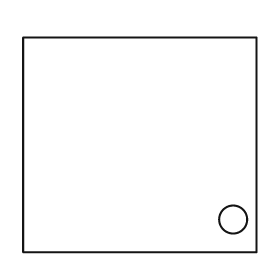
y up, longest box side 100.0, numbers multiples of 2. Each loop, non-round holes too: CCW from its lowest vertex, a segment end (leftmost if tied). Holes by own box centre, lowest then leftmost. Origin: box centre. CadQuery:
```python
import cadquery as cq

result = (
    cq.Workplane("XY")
    .moveTo(-50.0, -46.0)
    .lineTo(50.0, -46.0)
    .lineTo(50.0, 46.0)
    .lineTo(-50.0, 46.0)
    .close()
    .moveTo(40.0, -32.0)
    .circle(6.0)
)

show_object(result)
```